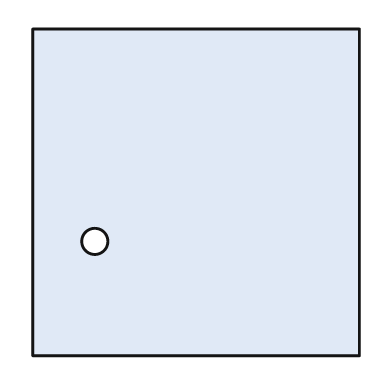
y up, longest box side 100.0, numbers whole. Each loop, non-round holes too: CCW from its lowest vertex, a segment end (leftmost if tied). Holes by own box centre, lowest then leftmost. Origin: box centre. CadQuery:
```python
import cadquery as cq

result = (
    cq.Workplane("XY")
    .moveTo(-50.0, -50.0)
    .lineTo(50.0, -50.0)
    .lineTo(50.0, 50.0)
    .lineTo(-50.0, 50.0)
    .close()
    .moveTo(-31.0, -15.0)
    .circle(4.0)
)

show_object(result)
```